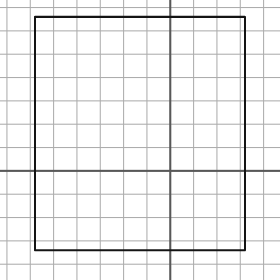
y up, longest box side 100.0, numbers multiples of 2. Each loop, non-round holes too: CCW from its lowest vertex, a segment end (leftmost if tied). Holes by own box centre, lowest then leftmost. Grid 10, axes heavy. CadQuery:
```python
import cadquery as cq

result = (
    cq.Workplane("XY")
    .moveTo(-58.0, -34.0)
    .lineTo(32.0, -34.0)
    .lineTo(32.0, 66.0)
    .lineTo(-58.0, 66.0)
    .close()
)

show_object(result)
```